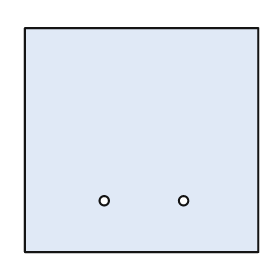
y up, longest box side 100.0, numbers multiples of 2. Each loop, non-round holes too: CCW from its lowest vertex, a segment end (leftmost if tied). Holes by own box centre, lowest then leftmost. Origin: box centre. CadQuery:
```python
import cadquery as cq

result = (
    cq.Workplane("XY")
    .moveTo(-50.0, -48.0)
    .lineTo(50.0, -48.0)
    .lineTo(50.0, 48.0)
    .lineTo(-50.0, 48.0)
    .close()
    .moveTo(-16.0, -26.0)
    .circle(2.0)
    .moveTo(18.0, -26.0)
    .circle(2.0)
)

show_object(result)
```